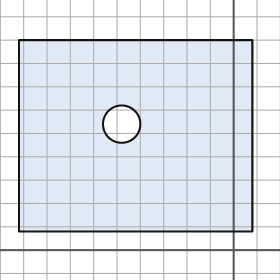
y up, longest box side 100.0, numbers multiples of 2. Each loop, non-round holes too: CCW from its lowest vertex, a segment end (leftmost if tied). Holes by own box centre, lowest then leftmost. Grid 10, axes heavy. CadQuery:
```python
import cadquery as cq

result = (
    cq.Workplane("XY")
    .moveTo(-92.0, 8.0)
    .lineTo(8.0, 8.0)
    .lineTo(8.0, 90.0)
    .lineTo(-92.0, 90.0)
    .close()
    .moveTo(-48.0, 54.0)
    .circle(8.0)
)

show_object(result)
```